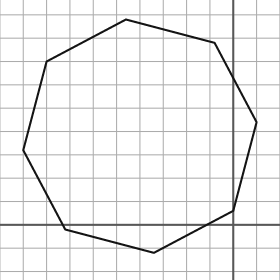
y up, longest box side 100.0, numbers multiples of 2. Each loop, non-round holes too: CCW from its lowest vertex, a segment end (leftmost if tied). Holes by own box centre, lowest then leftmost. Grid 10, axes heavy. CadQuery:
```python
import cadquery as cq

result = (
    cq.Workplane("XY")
    .moveTo(-34.0, -12.0)
    .lineTo(0.0, 6.0)
    .lineTo(10.0, 44.0)
    .lineTo(-8.0, 78.0)
    .lineTo(-46.0, 88.0)
    .lineTo(-80.0, 70.0)
    .lineTo(-90.0, 32.0)
    .lineTo(-72.0, -2.0)
    .close()
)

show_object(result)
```